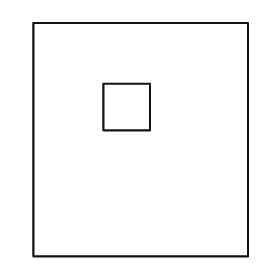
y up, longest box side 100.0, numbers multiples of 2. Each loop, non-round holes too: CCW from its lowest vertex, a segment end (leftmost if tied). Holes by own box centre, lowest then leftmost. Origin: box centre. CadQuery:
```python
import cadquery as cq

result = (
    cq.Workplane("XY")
    .moveTo(-46.0, -50.0)
    .lineTo(46.0, -50.0)
    .lineTo(46.0, 50.0)
    .lineTo(-46.0, 50.0)
    .close()
    .moveTo(-16.0, 4.0)
    .lineTo(4.0, 4.0)
    .lineTo(4.0, 24.0)
    .lineTo(-16.0, 24.0)
    .close()
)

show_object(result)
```